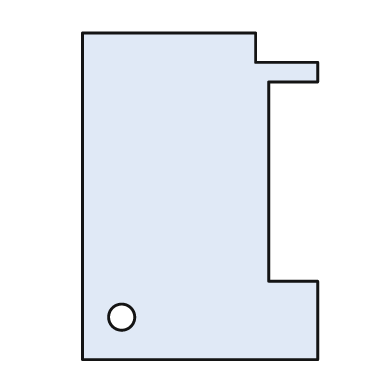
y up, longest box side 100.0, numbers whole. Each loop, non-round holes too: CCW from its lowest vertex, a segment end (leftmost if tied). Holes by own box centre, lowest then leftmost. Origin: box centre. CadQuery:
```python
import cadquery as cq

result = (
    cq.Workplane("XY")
    .moveTo(-36.0, -50.0)
    .lineTo(36.0, -50.0)
    .lineTo(36.0, -26.0)
    .lineTo(21.0, -26.0)
    .lineTo(21.0, 35.0)
    .lineTo(36.0, 35.0)
    .lineTo(36.0, 41.0)
    .lineTo(17.0, 41.0)
    .lineTo(17.0, 50.0)
    .lineTo(-36.0, 50.0)
    .close()
    .moveTo(-24.0, -37.0)
    .circle(4.0)
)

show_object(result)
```